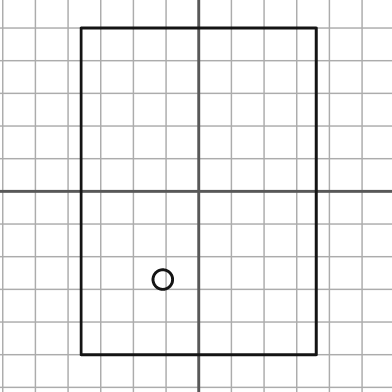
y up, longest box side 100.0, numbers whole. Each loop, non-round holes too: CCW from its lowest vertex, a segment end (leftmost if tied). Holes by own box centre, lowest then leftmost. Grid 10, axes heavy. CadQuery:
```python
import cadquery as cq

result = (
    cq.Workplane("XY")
    .moveTo(-36.0, -50.0)
    .lineTo(36.0, -50.0)
    .lineTo(36.0, 50.0)
    .lineTo(-36.0, 50.0)
    .close()
    .moveTo(-11.0, -27.0)
    .circle(3.0)
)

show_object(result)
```